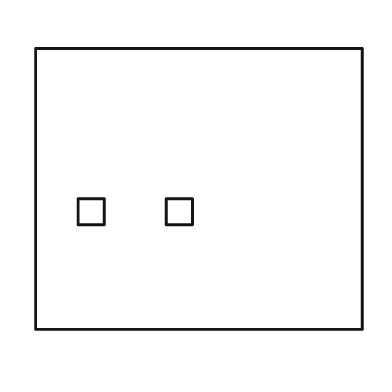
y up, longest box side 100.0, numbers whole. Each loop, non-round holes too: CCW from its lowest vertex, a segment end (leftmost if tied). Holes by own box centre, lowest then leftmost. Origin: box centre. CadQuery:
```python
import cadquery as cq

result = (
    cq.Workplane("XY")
    .moveTo(-50.0, -43.0)
    .lineTo(50.0, -43.0)
    .lineTo(50.0, 43.0)
    .lineTo(-50.0, 43.0)
    .close()
    .moveTo(-37.0, -11.0)
    .lineTo(-29.0, -11.0)
    .lineTo(-29.0, -3.0)
    .lineTo(-37.0, -3.0)
    .close()
    .moveTo(-10.0, -11.0)
    .lineTo(-2.0, -11.0)
    .lineTo(-2.0, -3.0)
    .lineTo(-10.0, -3.0)
    .close()
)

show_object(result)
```